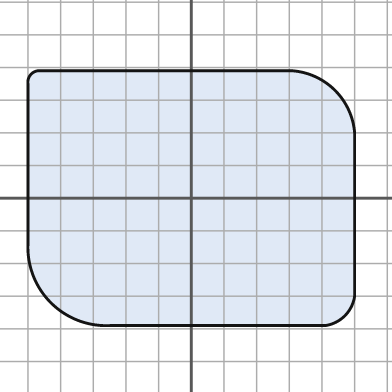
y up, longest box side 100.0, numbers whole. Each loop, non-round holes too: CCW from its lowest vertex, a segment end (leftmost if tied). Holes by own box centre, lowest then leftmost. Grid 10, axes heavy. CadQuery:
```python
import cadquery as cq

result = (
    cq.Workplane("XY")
    .moveTo(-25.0, -39.0)
    .lineTo(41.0, -39.0)
    .threePointArc((47.0, -36.0), (50.0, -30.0))
    .lineTo(50.0, 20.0)
    .threePointArc((44.0, 33.0), (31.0, 39.0))
    .lineTo(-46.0, 39.0)
    .threePointArc((-49.0, 38.0), (-50.0, 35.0))
    .lineTo(-50.0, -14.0)
    .threePointArc((-43.0, -32.0), (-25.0, -39.0))
    .close()
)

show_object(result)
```